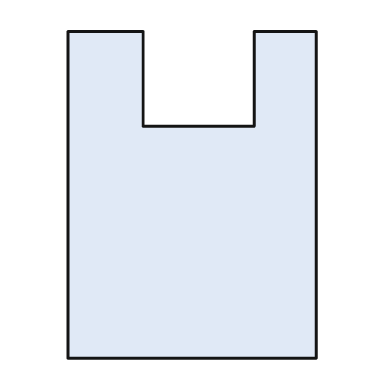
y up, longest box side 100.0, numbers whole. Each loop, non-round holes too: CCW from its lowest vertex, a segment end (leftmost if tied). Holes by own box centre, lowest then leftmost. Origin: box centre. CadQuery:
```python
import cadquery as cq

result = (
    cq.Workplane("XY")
    .moveTo(-38.0, -50.0)
    .lineTo(38.0, -50.0)
    .lineTo(38.0, 50.0)
    .lineTo(19.0, 50.0)
    .lineTo(19.0, 21.0)
    .lineTo(-15.0, 21.0)
    .lineTo(-15.0, 50.0)
    .lineTo(-38.0, 50.0)
    .close()
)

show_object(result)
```